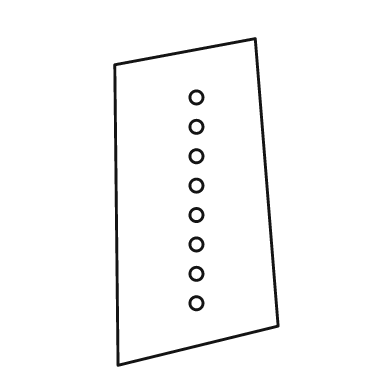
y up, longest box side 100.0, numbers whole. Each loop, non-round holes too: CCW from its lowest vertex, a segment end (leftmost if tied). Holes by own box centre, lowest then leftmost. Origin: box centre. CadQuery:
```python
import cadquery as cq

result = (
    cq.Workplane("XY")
    .moveTo(-24.0, -50.0)
    .lineTo(25.0, -38.0)
    .lineTo(18.0, 50.0)
    .lineTo(-25.0, 42.0)
    .close()
    .moveTo(0.0, -31.0)
    .circle(2.0)
    .moveTo(0.0, -22.0)
    .circle(2.0)
    .moveTo(0.0, -13.0)
    .circle(2.0)
    .moveTo(0.0, -4.0)
    .circle(2.0)
    .moveTo(0.0, 5.0)
    .circle(2.0)
    .moveTo(0.0, 14.0)
    .circle(2.0)
    .moveTo(0.0, 23.0)
    .circle(2.0)
    .moveTo(0.0, 32.0)
    .circle(2.0)
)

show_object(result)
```